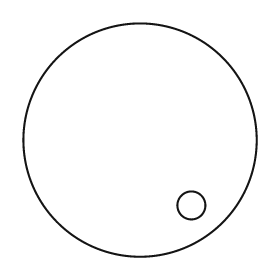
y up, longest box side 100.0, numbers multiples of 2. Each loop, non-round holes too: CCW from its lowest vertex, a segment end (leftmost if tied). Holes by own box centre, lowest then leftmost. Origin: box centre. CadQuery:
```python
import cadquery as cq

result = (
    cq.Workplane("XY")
    .moveTo(0.0, 0.0)
    .circle(50.0)
    .moveTo(22.0, -28.0)
    .circle(6.0)
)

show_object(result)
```